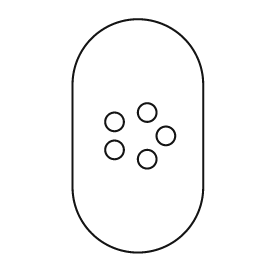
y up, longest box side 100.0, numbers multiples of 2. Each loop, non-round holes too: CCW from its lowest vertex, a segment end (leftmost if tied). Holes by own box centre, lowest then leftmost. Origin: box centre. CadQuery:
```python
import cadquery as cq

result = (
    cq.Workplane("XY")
    .moveTo(-28.0, -22.0)
    .threePointArc((0.0, -50.0), (28.0, -22.0))
    .lineTo(28.0, 22.0)
    .threePointArc((0.0, 50.0), (-28.0, 22.0))
    .close()
    .moveTo(4.0, -10.0)
    .circle(4.0)
    .moveTo(-10.0, -6.0)
    .circle(4.0)
    .moveTo(12.0, 0.0)
    .circle(4.0)
    .moveTo(-10.0, 6.0)
    .circle(4.0)
    .moveTo(4.0, 10.0)
    .circle(4.0)
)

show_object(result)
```